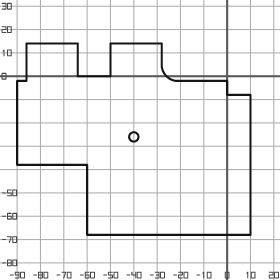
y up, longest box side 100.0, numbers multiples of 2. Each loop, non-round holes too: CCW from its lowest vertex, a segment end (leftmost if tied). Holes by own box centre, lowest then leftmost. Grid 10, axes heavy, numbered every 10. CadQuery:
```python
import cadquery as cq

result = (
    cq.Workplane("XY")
    .moveTo(-60.0, -68.0)
    .lineTo(10.0, -68.0)
    .lineTo(10.0, -8.0)
    .lineTo(0.0, -8.0)
    .lineTo(0.0, -2.0)
    .lineTo(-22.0, -2.0)
    .threePointArc((-26.0, 0.0), (-28.0, 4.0))
    .lineTo(-28.0, 14.0)
    .lineTo(-50.0, 14.0)
    .lineTo(-50.0, 0.0)
    .lineTo(-64.0, 0.0)
    .lineTo(-64.0, 14.0)
    .lineTo(-86.0, 14.0)
    .lineTo(-86.0, -2.0)
    .lineTo(-90.0, -2.0)
    .lineTo(-90.0, -38.0)
    .lineTo(-60.0, -38.0)
    .close()
    .moveTo(-40.0, -26.0)
    .circle(2.0)
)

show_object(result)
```